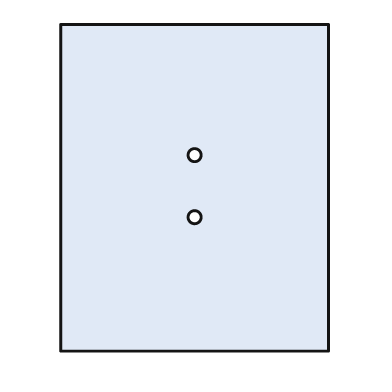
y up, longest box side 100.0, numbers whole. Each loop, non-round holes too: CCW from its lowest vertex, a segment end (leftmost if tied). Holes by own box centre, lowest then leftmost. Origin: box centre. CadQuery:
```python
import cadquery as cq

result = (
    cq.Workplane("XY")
    .moveTo(-41.0, -50.0)
    .lineTo(41.0, -50.0)
    .lineTo(41.0, 50.0)
    .lineTo(-41.0, 50.0)
    .close()
    .moveTo(0.0, -9.0)
    .circle(2.0)
    .moveTo(0.0, 10.0)
    .circle(2.0)
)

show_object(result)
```